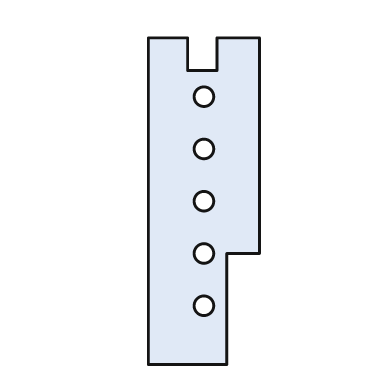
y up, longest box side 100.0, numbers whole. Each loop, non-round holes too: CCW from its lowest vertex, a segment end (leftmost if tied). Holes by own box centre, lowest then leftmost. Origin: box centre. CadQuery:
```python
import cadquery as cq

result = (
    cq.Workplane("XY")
    .moveTo(-17.0, -50.0)
    .lineTo(7.0, -50.0)
    .lineTo(7.0, -16.0)
    .lineTo(17.0, -16.0)
    .lineTo(17.0, 50.0)
    .lineTo(4.0, 50.0)
    .lineTo(4.0, 40.0)
    .lineTo(-5.0, 40.0)
    .lineTo(-5.0, 50.0)
    .lineTo(-17.0, 50.0)
    .close()
    .moveTo(0.0, -32.0)
    .circle(3.0)
    .moveTo(0.0, -16.0)
    .circle(3.0)
    .moveTo(0.0, 0.0)
    .circle(3.0)
    .moveTo(0.0, 16.0)
    .circle(3.0)
    .moveTo(0.0, 32.0)
    .circle(3.0)
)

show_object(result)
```